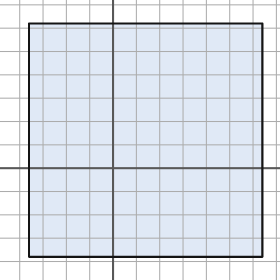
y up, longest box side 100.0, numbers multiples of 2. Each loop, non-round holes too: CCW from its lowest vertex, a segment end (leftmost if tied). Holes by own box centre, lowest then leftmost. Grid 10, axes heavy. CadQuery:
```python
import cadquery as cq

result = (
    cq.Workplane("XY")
    .moveTo(-36.0, -38.0)
    .lineTo(64.0, -38.0)
    .lineTo(64.0, 62.0)
    .lineTo(-36.0, 62.0)
    .close()
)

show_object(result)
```